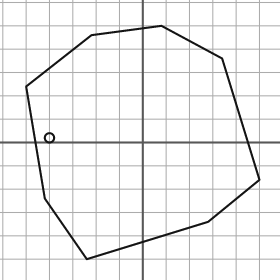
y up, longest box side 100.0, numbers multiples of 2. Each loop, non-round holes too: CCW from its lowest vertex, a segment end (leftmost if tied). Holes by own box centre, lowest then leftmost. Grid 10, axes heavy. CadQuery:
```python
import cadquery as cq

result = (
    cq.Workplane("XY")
    .moveTo(-24.0, -50.0)
    .lineTo(28.0, -34.0)
    .lineTo(50.0, -16.0)
    .lineTo(34.0, 36.0)
    .lineTo(8.0, 50.0)
    .lineTo(-22.0, 46.0)
    .lineTo(-50.0, 24.0)
    .lineTo(-42.0, -24.0)
    .close()
    .moveTo(-40.0, 2.0)
    .circle(2.0)
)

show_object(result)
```